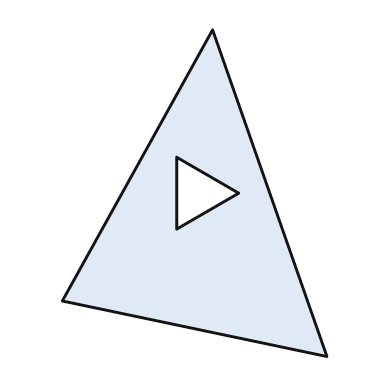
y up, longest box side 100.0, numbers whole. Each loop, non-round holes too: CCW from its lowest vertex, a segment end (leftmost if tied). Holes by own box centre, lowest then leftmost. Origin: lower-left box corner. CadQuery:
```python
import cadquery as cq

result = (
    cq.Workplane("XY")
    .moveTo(81.0, 0.0)
    .lineTo(46.0, 100.0)
    .lineTo(0.0, 17.0)
    .close()
    .moveTo(35.0, 39.0)
    .lineTo(54.0, 50.0)
    .lineTo(35.0, 61.0)
    .close()
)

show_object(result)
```